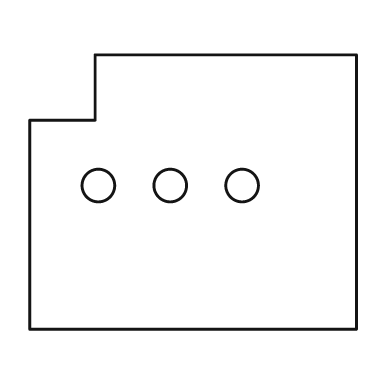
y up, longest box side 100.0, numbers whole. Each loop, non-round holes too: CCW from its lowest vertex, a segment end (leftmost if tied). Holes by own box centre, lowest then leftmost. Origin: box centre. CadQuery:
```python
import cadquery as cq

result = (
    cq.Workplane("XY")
    .moveTo(-50.0, -42.0)
    .lineTo(50.0, -42.0)
    .lineTo(50.0, 42.0)
    .lineTo(-30.0, 42.0)
    .lineTo(-30.0, 22.0)
    .lineTo(-50.0, 22.0)
    .close()
    .moveTo(-29.0, 2.0)
    .circle(5.0)
    .moveTo(-7.0, 2.0)
    .circle(5.0)
    .moveTo(15.0, 2.0)
    .circle(5.0)
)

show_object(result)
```